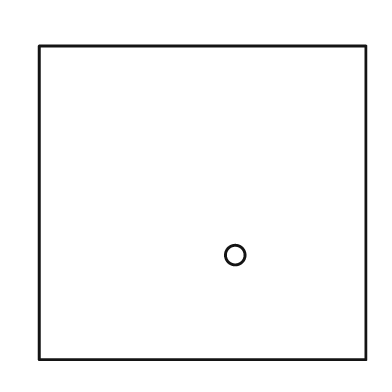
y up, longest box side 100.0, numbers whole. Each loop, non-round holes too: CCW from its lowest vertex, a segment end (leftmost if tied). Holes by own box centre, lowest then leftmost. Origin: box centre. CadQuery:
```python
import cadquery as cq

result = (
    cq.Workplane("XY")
    .moveTo(-50.0, -48.0)
    .lineTo(50.0, -48.0)
    .lineTo(50.0, 48.0)
    .lineTo(-50.0, 48.0)
    .close()
    .moveTo(10.0, -16.0)
    .circle(3.0)
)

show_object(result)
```